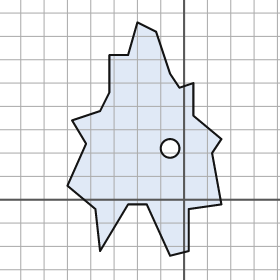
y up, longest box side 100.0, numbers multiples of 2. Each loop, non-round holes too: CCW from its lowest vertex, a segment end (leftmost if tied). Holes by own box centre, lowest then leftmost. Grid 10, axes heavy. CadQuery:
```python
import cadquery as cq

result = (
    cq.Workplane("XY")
    .moveTo(-6.0, -24.0)
    .lineTo(2.0, -22.0)
    .lineTo(2.0, -4.0)
    .lineTo(16.0, -2.0)
    .lineTo(12.0, 20.0)
    .lineTo(16.0, 26.0)
    .lineTo(4.0, 36.0)
    .lineTo(4.0, 50.0)
    .lineTo(-2.0, 48.0)
    .lineTo(-6.0, 54.0)
    .lineTo(-12.0, 72.0)
    .lineTo(-20.0, 76.0)
    .lineTo(-24.0, 62.0)
    .lineTo(-32.0, 62.0)
    .lineTo(-32.0, 46.0)
    .lineTo(-36.0, 38.0)
    .lineTo(-48.0, 34.0)
    .lineTo(-42.0, 24.0)
    .lineTo(-50.0, 6.0)
    .lineTo(-38.0, -4.0)
    .lineTo(-36.0, -22.0)
    .lineTo(-24.0, -2.0)
    .lineTo(-16.0, -2.0)
    .close()
    .moveTo(-6.0, 22.0)
    .circle(4.0)
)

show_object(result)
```